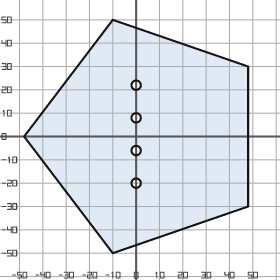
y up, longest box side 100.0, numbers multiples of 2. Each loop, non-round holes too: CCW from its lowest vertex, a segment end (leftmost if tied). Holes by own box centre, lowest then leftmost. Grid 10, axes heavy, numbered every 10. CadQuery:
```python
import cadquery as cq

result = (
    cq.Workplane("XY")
    .moveTo(-10.0, -50.0)
    .lineTo(48.0, -30.0)
    .lineTo(48.0, 30.0)
    .lineTo(-10.0, 50.0)
    .lineTo(-48.0, 0.0)
    .close()
    .moveTo(0.0, -20.0)
    .circle(2.0)
    .moveTo(0.0, -6.0)
    .circle(2.0)
    .moveTo(0.0, 8.0)
    .circle(2.0)
    .moveTo(0.0, 22.0)
    .circle(2.0)
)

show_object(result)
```